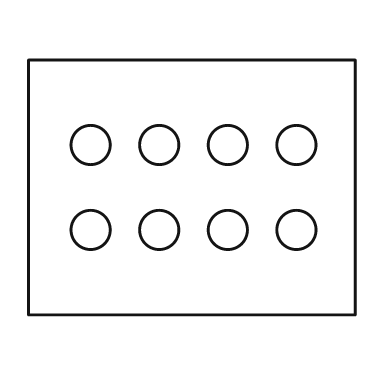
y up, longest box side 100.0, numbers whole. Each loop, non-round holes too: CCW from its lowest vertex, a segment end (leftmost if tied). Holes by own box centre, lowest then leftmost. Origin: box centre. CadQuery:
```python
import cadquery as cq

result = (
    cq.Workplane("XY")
    .moveTo(-50.0, -39.0)
    .lineTo(50.0, -39.0)
    .lineTo(50.0, 39.0)
    .lineTo(-50.0, 39.0)
    .close()
    .moveTo(-31.0, -13.0)
    .circle(6.0)
    .moveTo(-10.0, -13.0)
    .circle(6.0)
    .moveTo(11.0, -13.0)
    .circle(6.0)
    .moveTo(32.0, -13.0)
    .circle(6.0)
    .moveTo(-31.0, 13.0)
    .circle(6.0)
    .moveTo(-10.0, 13.0)
    .circle(6.0)
    .moveTo(11.0, 13.0)
    .circle(6.0)
    .moveTo(32.0, 13.0)
    .circle(6.0)
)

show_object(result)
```